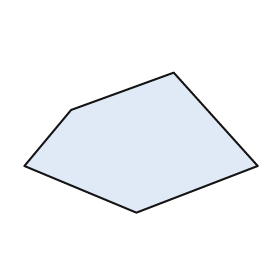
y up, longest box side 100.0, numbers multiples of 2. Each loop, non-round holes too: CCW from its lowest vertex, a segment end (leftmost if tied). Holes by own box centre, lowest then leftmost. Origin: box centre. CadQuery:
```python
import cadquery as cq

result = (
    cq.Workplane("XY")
    .moveTo(-2.0, -30.0)
    .lineTo(50.0, -10.0)
    .lineTo(14.0, 30.0)
    .lineTo(-30.0, 14.0)
    .lineTo(-50.0, -10.0)
    .close()
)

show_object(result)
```